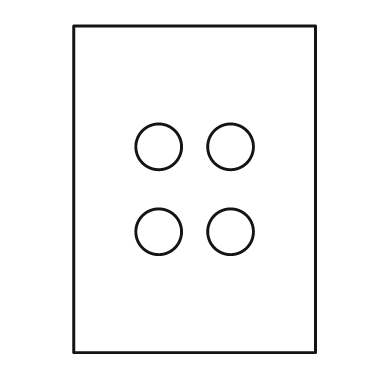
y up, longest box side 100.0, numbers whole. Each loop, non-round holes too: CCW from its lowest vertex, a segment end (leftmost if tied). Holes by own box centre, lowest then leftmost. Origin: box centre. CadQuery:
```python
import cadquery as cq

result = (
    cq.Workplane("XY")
    .moveTo(-37.0, -50.0)
    .lineTo(37.0, -50.0)
    .lineTo(37.0, 50.0)
    .lineTo(-37.0, 50.0)
    .close()
    .moveTo(-11.0, -13.0)
    .circle(7.0)
    .moveTo(11.0, -13.0)
    .circle(7.0)
    .moveTo(-11.0, 13.0)
    .circle(7.0)
    .moveTo(11.0, 13.0)
    .circle(7.0)
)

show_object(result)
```